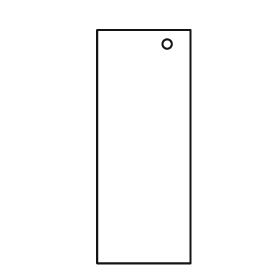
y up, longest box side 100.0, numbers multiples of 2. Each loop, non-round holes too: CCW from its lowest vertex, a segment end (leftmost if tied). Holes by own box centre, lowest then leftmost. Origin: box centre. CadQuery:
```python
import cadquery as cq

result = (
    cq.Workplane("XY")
    .moveTo(-20.0, -50.0)
    .lineTo(20.0, -50.0)
    .lineTo(20.0, 50.0)
    .lineTo(-20.0, 50.0)
    .close()
    .moveTo(10.0, 44.0)
    .circle(2.0)
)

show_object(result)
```